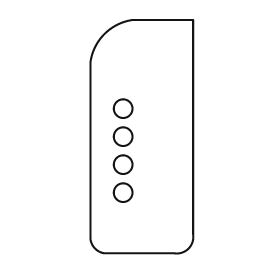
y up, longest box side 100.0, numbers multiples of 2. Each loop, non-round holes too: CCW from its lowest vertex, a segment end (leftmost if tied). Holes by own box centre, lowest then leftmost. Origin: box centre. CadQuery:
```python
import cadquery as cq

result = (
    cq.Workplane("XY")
    .moveTo(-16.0, -50.0)
    .lineTo(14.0, -50.0)
    .threePointArc((20.0, -48.0), (22.0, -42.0))
    .lineTo(22.0, 50.0)
    .lineTo(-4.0, 50.0)
    .threePointArc((-16.0, 44.0), (-22.0, 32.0))
    .lineTo(-22.0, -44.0)
    .threePointArc((-20.0, -48.0), (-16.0, -50.0))
    .close()
    .moveTo(-8.0, -24.0)
    .circle(4.0)
    .moveTo(-8.0, -12.0)
    .circle(4.0)
    .moveTo(-8.0, 0.0)
    .circle(4.0)
    .moveTo(-8.0, 12.0)
    .circle(4.0)
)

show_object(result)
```